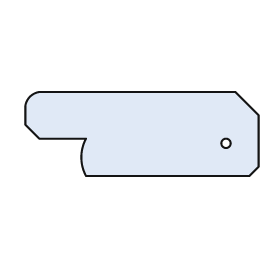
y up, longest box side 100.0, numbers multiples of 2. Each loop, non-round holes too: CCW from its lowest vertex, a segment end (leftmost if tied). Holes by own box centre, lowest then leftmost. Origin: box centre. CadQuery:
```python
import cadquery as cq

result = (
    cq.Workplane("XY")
    .moveTo(-24.0, -18.0)
    .lineTo(46.0, -18.0)
    .lineTo(50.0, -14.0)
    .lineTo(50.0, 8.0)
    .lineTo(40.0, 18.0)
    .lineTo(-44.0, 18.0)
    .threePointArc((-48.0, 16.0), (-50.0, 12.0))
    .lineTo(-50.0, 4.0)
    .lineTo(-44.0, -2.0)
    .lineTo(-24.0, -2.0)
    .threePointArc((-26.0, -10.0), (-24.0, -18.0))
    .close()
    .moveTo(36.0, -4.0)
    .circle(2.0)
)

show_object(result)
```